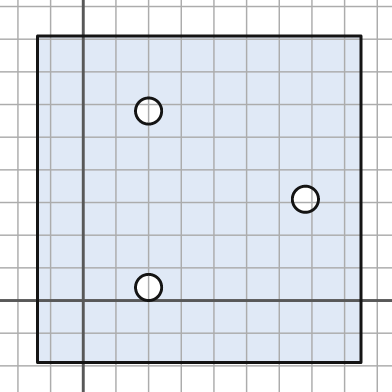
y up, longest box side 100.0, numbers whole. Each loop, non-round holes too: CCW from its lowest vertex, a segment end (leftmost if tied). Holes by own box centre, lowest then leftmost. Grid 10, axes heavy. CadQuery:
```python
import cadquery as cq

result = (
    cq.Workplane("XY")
    .moveTo(-14.0, -19.0)
    .lineTo(85.0, -19.0)
    .lineTo(85.0, 81.0)
    .lineTo(-14.0, 81.0)
    .close()
    .moveTo(20.0, 4.0)
    .circle(4.0)
    .moveTo(68.0, 31.0)
    .circle(4.0)
    .moveTo(20.0, 58.0)
    .circle(4.0)
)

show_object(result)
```